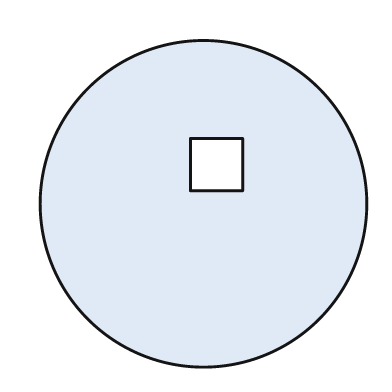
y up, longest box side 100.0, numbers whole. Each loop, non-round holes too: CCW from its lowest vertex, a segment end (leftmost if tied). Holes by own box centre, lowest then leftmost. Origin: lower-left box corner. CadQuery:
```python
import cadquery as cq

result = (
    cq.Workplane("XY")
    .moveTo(50.0, 50.0)
    .circle(50.0)
    .moveTo(46.0, 54.0)
    .lineTo(62.0, 54.0)
    .lineTo(62.0, 70.0)
    .lineTo(46.0, 70.0)
    .close()
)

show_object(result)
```